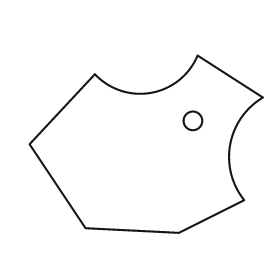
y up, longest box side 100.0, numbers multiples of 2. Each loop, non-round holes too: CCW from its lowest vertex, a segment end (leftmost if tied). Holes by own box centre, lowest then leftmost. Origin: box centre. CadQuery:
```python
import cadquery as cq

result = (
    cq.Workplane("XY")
    .moveTo(14.0, -38.0)
    .lineTo(42.0, -24.0)
    .threePointArc((36.0, 0.0), (50.0, 20.0))
    .lineTo(22.0, 38.0)
    .threePointArc((2.0, 22.0), (-22.0, 30.0))
    .lineTo(-50.0, 0.0)
    .lineTo(-26.0, -36.0)
    .close()
    .moveTo(20.0, 10.0)
    .circle(4.0)
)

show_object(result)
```